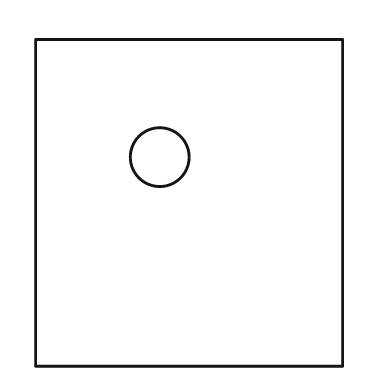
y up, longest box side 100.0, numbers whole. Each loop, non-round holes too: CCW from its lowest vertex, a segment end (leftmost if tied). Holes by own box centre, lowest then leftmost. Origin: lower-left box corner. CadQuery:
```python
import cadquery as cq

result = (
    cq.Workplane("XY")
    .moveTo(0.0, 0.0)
    .lineTo(94.0, 0.0)
    .lineTo(94.0, 100.0)
    .lineTo(0.0, 100.0)
    .close()
    .moveTo(38.0, 64.0)
    .circle(9.0)
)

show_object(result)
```